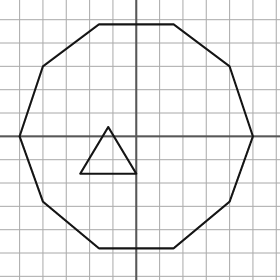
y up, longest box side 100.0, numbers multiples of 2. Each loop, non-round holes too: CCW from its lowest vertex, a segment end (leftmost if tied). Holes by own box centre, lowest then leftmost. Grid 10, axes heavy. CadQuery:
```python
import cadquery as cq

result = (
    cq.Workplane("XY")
    .moveTo(-16.0, -48.0)
    .lineTo(16.0, -48.0)
    .lineTo(40.0, -28.0)
    .lineTo(50.0, 0.0)
    .lineTo(40.0, 30.0)
    .lineTo(16.0, 48.0)
    .lineTo(-16.0, 48.0)
    .lineTo(-40.0, 30.0)
    .lineTo(-50.0, 0.0)
    .lineTo(-40.0, -28.0)
    .close()
    .moveTo(-24.0, -16.0)
    .lineTo(0.0, -16.0)
    .lineTo(-12.0, 4.0)
    .close()
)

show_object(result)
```